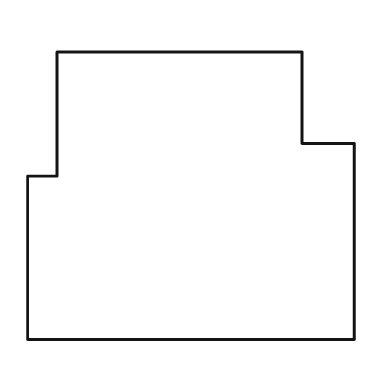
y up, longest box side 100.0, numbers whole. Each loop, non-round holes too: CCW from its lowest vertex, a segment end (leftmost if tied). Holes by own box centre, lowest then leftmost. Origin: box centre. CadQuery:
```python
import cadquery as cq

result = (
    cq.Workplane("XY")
    .moveTo(-50.0, -44.0)
    .lineTo(50.0, -44.0)
    .lineTo(50.0, 16.0)
    .lineTo(34.0, 16.0)
    .lineTo(34.0, 44.0)
    .lineTo(-41.0, 44.0)
    .lineTo(-41.0, 6.0)
    .lineTo(-50.0, 6.0)
    .close()
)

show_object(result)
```